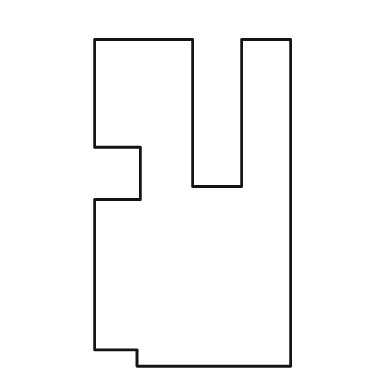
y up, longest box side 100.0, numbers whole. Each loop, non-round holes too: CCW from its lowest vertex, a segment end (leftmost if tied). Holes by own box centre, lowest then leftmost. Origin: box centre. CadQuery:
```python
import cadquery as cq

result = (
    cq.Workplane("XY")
    .moveTo(-17.0, -50.0)
    .lineTo(30.0, -50.0)
    .lineTo(30.0, 50.0)
    .lineTo(15.0, 50.0)
    .lineTo(15.0, 5.0)
    .lineTo(0.0, 5.0)
    .lineTo(0.0, 50.0)
    .lineTo(-30.0, 50.0)
    .lineTo(-30.0, 17.0)
    .lineTo(-16.0, 17.0)
    .lineTo(-16.0, 1.0)
    .lineTo(-30.0, 1.0)
    .lineTo(-30.0, -45.0)
    .lineTo(-17.0, -45.0)
    .close()
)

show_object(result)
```